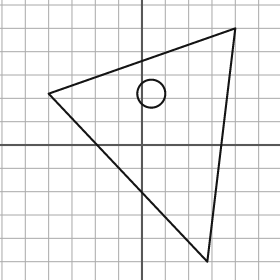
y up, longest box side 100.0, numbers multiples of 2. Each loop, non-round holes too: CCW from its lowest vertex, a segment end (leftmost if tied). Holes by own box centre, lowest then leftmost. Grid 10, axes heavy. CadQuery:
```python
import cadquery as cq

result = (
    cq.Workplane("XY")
    .moveTo(28.0, -50.0)
    .lineTo(40.0, 50.0)
    .lineTo(-40.0, 22.0)
    .close()
    .moveTo(4.0, 22.0)
    .circle(6.0)
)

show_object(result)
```